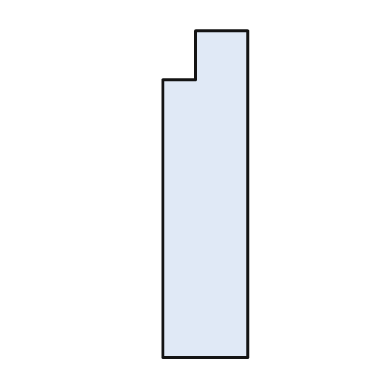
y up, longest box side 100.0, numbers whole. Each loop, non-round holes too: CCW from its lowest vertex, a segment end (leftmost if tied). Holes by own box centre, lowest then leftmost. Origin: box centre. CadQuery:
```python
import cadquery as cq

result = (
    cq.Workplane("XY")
    .moveTo(-13.0, -50.0)
    .lineTo(13.0, -50.0)
    .lineTo(13.0, 50.0)
    .lineTo(-3.0, 50.0)
    .lineTo(-3.0, 35.0)
    .lineTo(-13.0, 35.0)
    .close()
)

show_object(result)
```